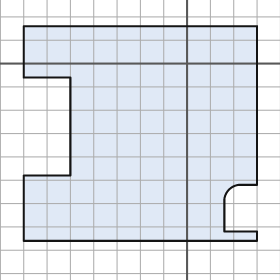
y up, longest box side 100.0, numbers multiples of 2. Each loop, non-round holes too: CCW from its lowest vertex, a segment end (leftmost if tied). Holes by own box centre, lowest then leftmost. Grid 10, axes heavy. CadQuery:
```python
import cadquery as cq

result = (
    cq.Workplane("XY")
    .moveTo(-70.0, -76.0)
    .lineTo(30.0, -76.0)
    .lineTo(30.0, -72.0)
    .lineTo(16.0, -72.0)
    .lineTo(16.0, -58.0)
    .threePointArc((18.0, -54.0), (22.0, -52.0))
    .lineTo(30.0, -52.0)
    .lineTo(30.0, 16.0)
    .lineTo(-70.0, 16.0)
    .lineTo(-70.0, -6.0)
    .lineTo(-50.0, -6.0)
    .lineTo(-50.0, -48.0)
    .lineTo(-70.0, -48.0)
    .close()
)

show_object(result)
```